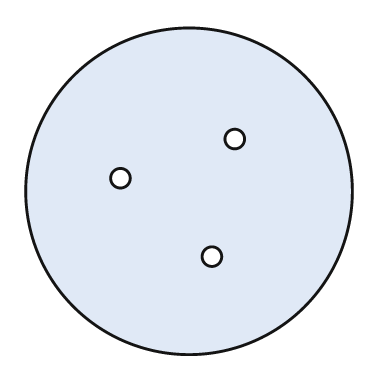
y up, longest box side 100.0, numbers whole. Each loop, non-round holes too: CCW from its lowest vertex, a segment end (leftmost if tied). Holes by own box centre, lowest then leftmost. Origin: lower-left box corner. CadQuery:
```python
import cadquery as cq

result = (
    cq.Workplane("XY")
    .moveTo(50.0, 50.0)
    .circle(50.0)
    .moveTo(57.0, 30.0)
    .circle(3.0)
    .moveTo(29.0, 54.0)
    .circle(3.0)
    .moveTo(64.0, 66.0)
    .circle(3.0)
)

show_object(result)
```